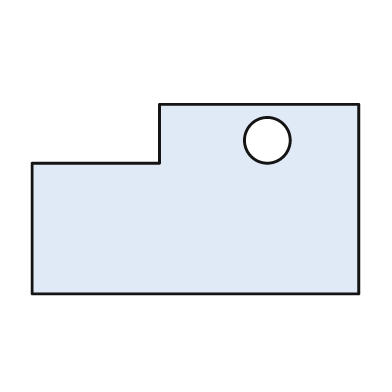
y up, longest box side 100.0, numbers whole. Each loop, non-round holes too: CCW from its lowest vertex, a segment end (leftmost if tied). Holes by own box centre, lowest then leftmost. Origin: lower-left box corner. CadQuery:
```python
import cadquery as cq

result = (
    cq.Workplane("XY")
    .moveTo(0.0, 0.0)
    .lineTo(100.0, 0.0)
    .lineTo(100.0, 58.0)
    .lineTo(39.0, 58.0)
    .lineTo(39.0, 40.0)
    .lineTo(0.0, 40.0)
    .close()
    .moveTo(72.0, 47.0)
    .circle(7.0)
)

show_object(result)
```